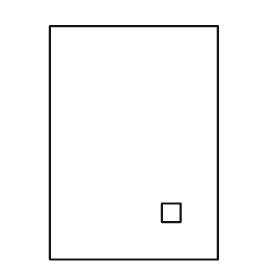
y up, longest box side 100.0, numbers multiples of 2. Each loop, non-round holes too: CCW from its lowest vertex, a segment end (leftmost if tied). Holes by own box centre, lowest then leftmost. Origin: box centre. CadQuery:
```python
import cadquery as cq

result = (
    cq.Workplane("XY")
    .moveTo(-36.0, -50.0)
    .lineTo(36.0, -50.0)
    .lineTo(36.0, 50.0)
    .lineTo(-36.0, 50.0)
    .close()
    .moveTo(12.0, -34.0)
    .lineTo(20.0, -34.0)
    .lineTo(20.0, -26.0)
    .lineTo(12.0, -26.0)
    .close()
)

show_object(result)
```